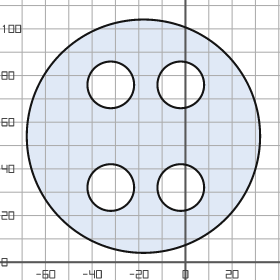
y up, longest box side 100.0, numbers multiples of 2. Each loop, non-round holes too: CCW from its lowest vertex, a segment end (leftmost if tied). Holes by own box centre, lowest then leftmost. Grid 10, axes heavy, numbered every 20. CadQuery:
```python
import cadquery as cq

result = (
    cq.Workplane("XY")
    .moveTo(-18.0, 54.0)
    .circle(50.0)
    .moveTo(-32.0, 32.0)
    .circle(10.0)
    .moveTo(-2.0, 32.0)
    .circle(10.0)
    .moveTo(-32.0, 76.0)
    .circle(10.0)
    .moveTo(-2.0, 76.0)
    .circle(10.0)
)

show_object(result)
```